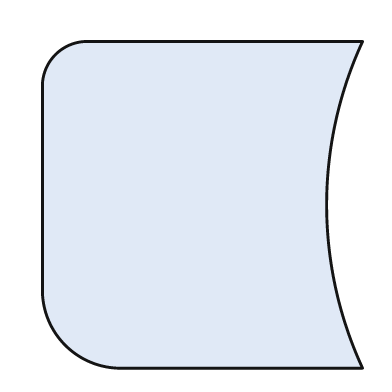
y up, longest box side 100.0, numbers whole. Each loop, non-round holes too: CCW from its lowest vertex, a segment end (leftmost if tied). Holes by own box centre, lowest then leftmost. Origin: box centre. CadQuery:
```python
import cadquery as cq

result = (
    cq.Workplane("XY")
    .moveTo(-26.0, -50.0)
    .lineTo(49.0, -50.0)
    .threePointArc((38.0, 0.0), (49.0, 50.0))
    .lineTo(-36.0, 50.0)
    .threePointArc((-45.0, 46.0), (-49.0, 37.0))
    .lineTo(-49.0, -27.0)
    .threePointArc((-42.0, -43.0), (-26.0, -50.0))
    .close()
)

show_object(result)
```